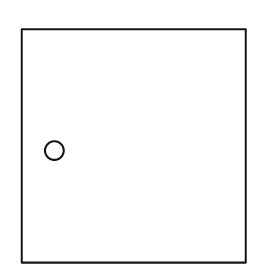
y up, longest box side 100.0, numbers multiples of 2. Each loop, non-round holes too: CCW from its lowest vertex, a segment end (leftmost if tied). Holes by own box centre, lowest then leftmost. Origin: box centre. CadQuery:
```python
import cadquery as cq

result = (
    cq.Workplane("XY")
    .moveTo(-48.0, -50.0)
    .lineTo(48.0, -50.0)
    .lineTo(48.0, 50.0)
    .lineTo(-48.0, 50.0)
    .close()
    .moveTo(-34.0, -2.0)
    .circle(4.0)
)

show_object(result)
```